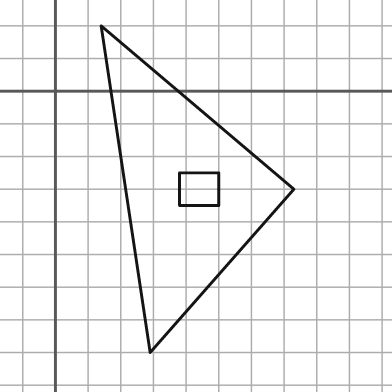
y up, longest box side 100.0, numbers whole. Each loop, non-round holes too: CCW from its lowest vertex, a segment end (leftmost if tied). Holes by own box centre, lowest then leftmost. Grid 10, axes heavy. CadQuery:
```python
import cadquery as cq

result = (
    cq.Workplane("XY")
    .moveTo(29.0, -80.0)
    .lineTo(73.0, -30.0)
    .lineTo(14.0, 20.0)
    .close()
    .moveTo(38.0, -35.0)
    .lineTo(50.0, -35.0)
    .lineTo(50.0, -25.0)
    .lineTo(38.0, -25.0)
    .close()
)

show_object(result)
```